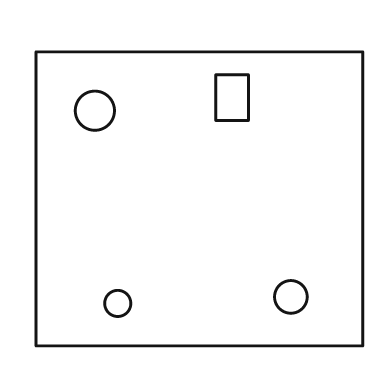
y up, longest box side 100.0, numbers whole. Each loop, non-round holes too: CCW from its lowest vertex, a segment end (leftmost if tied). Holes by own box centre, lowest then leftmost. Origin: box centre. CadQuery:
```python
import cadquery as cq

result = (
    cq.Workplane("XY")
    .moveTo(-50.0, -45.0)
    .lineTo(50.0, -45.0)
    .lineTo(50.0, 45.0)
    .lineTo(-50.0, 45.0)
    .close()
    .moveTo(-25.0, -32.0)
    .circle(4.0)
    .moveTo(28.0, -30.0)
    .circle(5.0)
    .moveTo(-32.0, 27.0)
    .circle(6.0)
    .moveTo(5.0, 24.0)
    .lineTo(15.0, 24.0)
    .lineTo(15.0, 38.0)
    .lineTo(5.0, 38.0)
    .close()
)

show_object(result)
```